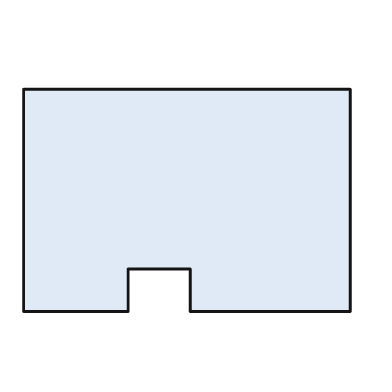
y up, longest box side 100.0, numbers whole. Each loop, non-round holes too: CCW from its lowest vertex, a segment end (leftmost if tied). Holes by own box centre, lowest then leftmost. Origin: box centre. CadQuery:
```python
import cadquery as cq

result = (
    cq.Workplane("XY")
    .moveTo(-50.0, -34.0)
    .lineTo(-18.0, -34.0)
    .lineTo(-18.0, -21.0)
    .lineTo(1.0, -21.0)
    .lineTo(1.0, -34.0)
    .lineTo(50.0, -34.0)
    .lineTo(50.0, 34.0)
    .lineTo(-50.0, 34.0)
    .close()
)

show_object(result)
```